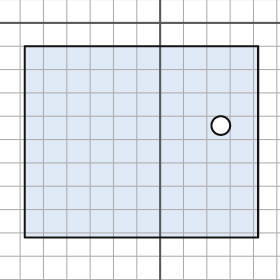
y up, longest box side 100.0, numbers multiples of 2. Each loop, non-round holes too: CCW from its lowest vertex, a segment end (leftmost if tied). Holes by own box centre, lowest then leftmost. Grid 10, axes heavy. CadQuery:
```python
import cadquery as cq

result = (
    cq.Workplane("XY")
    .moveTo(-58.0, -92.0)
    .lineTo(42.0, -92.0)
    .lineTo(42.0, -10.0)
    .lineTo(-58.0, -10.0)
    .close()
    .moveTo(26.0, -44.0)
    .circle(4.0)
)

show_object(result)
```